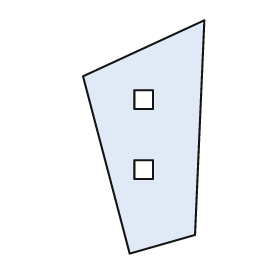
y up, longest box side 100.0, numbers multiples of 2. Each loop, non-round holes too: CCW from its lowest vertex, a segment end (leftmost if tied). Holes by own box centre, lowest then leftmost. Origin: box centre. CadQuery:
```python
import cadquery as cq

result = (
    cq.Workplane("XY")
    .moveTo(-6.0, -50.0)
    .lineTo(22.0, -42.0)
    .lineTo(26.0, 50.0)
    .lineTo(-26.0, 26.0)
    .close()
    .moveTo(-4.0, -18.0)
    .lineTo(4.0, -18.0)
    .lineTo(4.0, -10.0)
    .lineTo(-4.0, -10.0)
    .close()
    .moveTo(-4.0, 12.0)
    .lineTo(4.0, 12.0)
    .lineTo(4.0, 20.0)
    .lineTo(-4.0, 20.0)
    .close()
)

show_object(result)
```